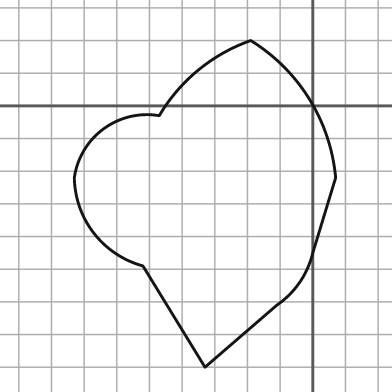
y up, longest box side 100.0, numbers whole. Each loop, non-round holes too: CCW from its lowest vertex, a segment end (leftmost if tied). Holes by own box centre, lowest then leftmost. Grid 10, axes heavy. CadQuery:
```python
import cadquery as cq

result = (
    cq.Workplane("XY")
    .moveTo(-33.0, -80.0)
    .lineTo(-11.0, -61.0)
    .threePointArc((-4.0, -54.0), (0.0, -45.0))
    .lineTo(7.0, -22.0)
    .threePointArc((-1.0, 2.0), (-19.0, 20.0))
    .threePointArc((-35.0, 11.0), (-47.0, -3.0))
    .threePointArc((-64.0, -7.0), (-73.0, -22.0))
    .threePointArc((-67.0, -39.0), (-52.0, -49.0))
    .close()
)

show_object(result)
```